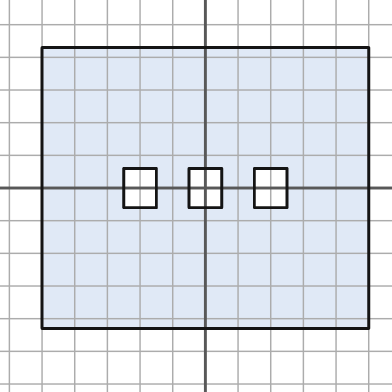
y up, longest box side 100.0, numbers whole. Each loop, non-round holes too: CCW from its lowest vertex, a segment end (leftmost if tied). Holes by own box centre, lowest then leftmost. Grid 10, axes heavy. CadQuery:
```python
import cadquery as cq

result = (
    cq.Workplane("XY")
    .moveTo(-50.0, -43.0)
    .lineTo(50.0, -43.0)
    .lineTo(50.0, 43.0)
    .lineTo(-50.0, 43.0)
    .close()
    .moveTo(-25.0, -6.0)
    .lineTo(-15.0, -6.0)
    .lineTo(-15.0, 6.0)
    .lineTo(-25.0, 6.0)
    .close()
    .moveTo(-5.0, -6.0)
    .lineTo(5.0, -6.0)
    .lineTo(5.0, 6.0)
    .lineTo(-5.0, 6.0)
    .close()
    .moveTo(15.0, -6.0)
    .lineTo(25.0, -6.0)
    .lineTo(25.0, 6.0)
    .lineTo(15.0, 6.0)
    .close()
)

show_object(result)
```